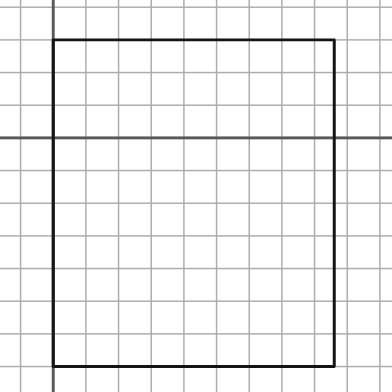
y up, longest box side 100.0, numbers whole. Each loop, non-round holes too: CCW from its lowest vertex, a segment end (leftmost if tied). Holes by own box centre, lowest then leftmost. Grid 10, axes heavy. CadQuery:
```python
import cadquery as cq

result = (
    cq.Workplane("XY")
    .moveTo(0.0, -70.0)
    .lineTo(86.0, -70.0)
    .lineTo(86.0, 30.0)
    .lineTo(0.0, 30.0)
    .close()
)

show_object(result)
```